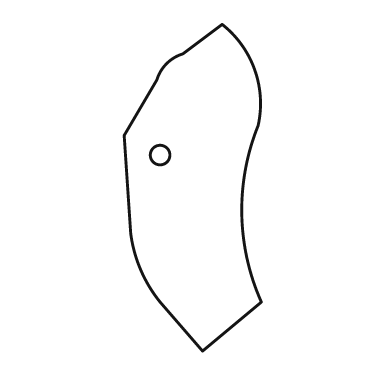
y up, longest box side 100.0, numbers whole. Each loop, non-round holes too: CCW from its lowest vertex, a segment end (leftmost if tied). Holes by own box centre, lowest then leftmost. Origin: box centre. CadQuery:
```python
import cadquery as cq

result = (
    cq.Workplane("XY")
    .moveTo(3.0, -50.0)
    .lineTo(21.0, -35.0)
    .threePointArc((15.0, -8.0), (20.0, 19.0))
    .threePointArc((19.0, 36.0), (9.0, 50.0))
    .lineTo(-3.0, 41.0)
    .threePointArc((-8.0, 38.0), (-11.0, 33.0))
    .lineTo(-21.0, 16.0)
    .lineTo(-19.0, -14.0)
    .threePointArc((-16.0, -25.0), (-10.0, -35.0))
    .close()
    .moveTo(-10.0, 10.0)
    .circle(3.0)
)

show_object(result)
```